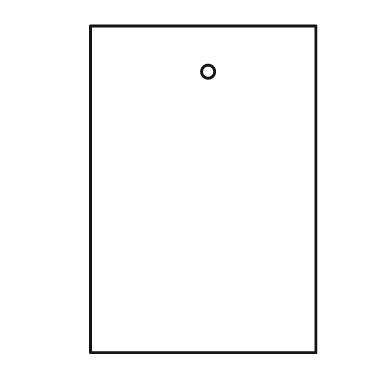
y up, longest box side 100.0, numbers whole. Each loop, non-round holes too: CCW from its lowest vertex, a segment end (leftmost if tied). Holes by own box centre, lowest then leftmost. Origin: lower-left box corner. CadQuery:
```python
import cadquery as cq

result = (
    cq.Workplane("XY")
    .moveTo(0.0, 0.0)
    .lineTo(69.0, 0.0)
    .lineTo(69.0, 100.0)
    .lineTo(0.0, 100.0)
    .close()
    .moveTo(36.0, 86.0)
    .circle(2.0)
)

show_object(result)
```